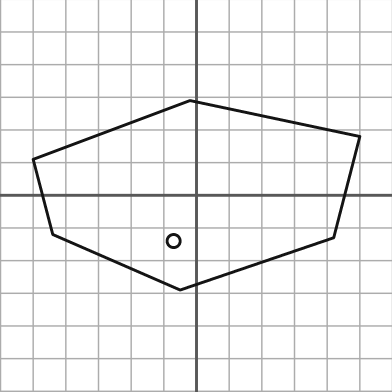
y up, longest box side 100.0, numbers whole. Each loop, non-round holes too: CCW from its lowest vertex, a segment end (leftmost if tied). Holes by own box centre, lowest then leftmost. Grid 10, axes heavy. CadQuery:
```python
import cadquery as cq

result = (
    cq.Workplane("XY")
    .moveTo(-5.0, -29.0)
    .lineTo(42.0, -13.0)
    .lineTo(50.0, 18.0)
    .lineTo(-2.0, 29.0)
    .lineTo(-50.0, 11.0)
    .lineTo(-44.0, -12.0)
    .close()
    .moveTo(-7.0, -14.0)
    .circle(2.0)
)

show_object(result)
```